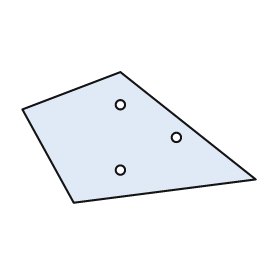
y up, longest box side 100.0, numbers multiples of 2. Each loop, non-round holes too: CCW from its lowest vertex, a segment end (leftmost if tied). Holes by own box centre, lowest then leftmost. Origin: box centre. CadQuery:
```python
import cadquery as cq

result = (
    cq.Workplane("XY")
    .moveTo(-28.0, -28.0)
    .lineTo(50.0, -18.0)
    .lineTo(-8.0, 28.0)
    .lineTo(-50.0, 12.0)
    .close()
    .moveTo(-8.0, -14.0)
    .circle(2.0)
    .moveTo(16.0, 0.0)
    .circle(2.0)
    .moveTo(-8.0, 14.0)
    .circle(2.0)
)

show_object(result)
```